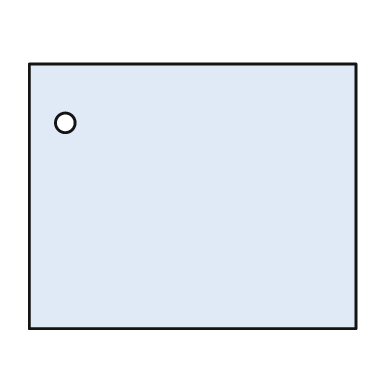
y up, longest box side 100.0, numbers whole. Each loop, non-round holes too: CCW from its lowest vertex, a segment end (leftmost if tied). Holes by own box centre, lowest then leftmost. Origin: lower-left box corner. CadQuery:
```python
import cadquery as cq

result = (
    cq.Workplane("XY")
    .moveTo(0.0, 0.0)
    .lineTo(100.0, 0.0)
    .lineTo(100.0, 81.0)
    .lineTo(0.0, 81.0)
    .close()
    .moveTo(11.0, 63.0)
    .circle(3.0)
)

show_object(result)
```